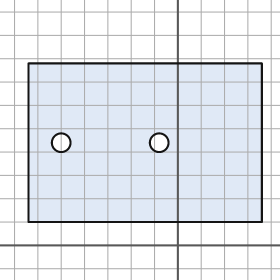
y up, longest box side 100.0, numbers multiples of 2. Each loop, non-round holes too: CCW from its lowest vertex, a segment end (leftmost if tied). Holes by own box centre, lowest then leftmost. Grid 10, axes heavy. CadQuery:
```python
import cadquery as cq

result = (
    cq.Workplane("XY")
    .moveTo(-64.0, 10.0)
    .lineTo(36.0, 10.0)
    .lineTo(36.0, 78.0)
    .lineTo(-64.0, 78.0)
    .close()
    .moveTo(-50.0, 44.0)
    .circle(4.0)
    .moveTo(-8.0, 44.0)
    .circle(4.0)
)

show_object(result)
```